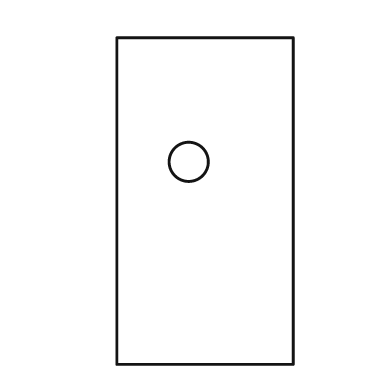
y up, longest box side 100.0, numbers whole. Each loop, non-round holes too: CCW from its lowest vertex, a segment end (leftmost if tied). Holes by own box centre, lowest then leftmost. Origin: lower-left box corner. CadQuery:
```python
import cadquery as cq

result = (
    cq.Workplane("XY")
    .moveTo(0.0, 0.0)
    .lineTo(54.0, 0.0)
    .lineTo(54.0, 100.0)
    .lineTo(0.0, 100.0)
    .close()
    .moveTo(22.0, 62.0)
    .circle(6.0)
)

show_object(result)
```